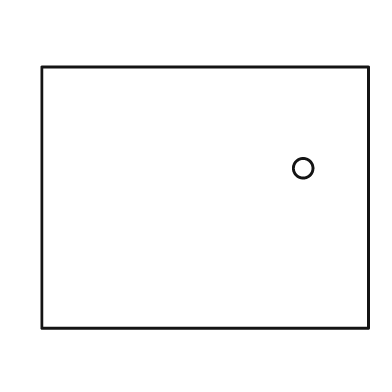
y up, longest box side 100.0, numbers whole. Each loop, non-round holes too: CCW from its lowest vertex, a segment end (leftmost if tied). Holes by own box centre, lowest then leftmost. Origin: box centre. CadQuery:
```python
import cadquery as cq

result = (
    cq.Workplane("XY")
    .moveTo(-50.0, -40.0)
    .lineTo(50.0, -40.0)
    .lineTo(50.0, 40.0)
    .lineTo(-50.0, 40.0)
    .close()
    .moveTo(30.0, 9.0)
    .circle(3.0)
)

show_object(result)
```